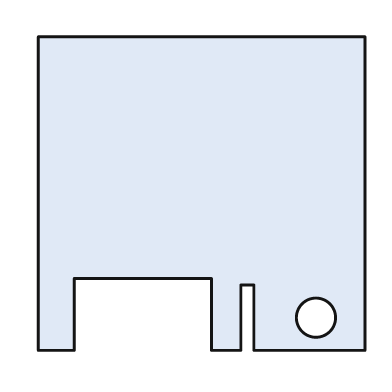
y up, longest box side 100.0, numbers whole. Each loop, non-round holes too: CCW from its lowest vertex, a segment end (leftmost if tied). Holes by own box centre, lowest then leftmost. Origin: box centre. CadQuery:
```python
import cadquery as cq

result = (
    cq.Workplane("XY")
    .moveTo(-50.0, -48.0)
    .lineTo(-39.0, -48.0)
    .lineTo(-39.0, -26.0)
    .lineTo(3.0, -26.0)
    .lineTo(3.0, -48.0)
    .lineTo(12.0, -48.0)
    .lineTo(12.0, -28.0)
    .lineTo(16.0, -28.0)
    .lineTo(16.0, -48.0)
    .lineTo(50.0, -48.0)
    .lineTo(50.0, 48.0)
    .lineTo(-50.0, 48.0)
    .close()
    .moveTo(35.0, -38.0)
    .circle(6.0)
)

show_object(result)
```